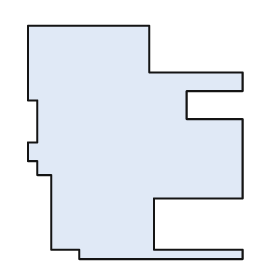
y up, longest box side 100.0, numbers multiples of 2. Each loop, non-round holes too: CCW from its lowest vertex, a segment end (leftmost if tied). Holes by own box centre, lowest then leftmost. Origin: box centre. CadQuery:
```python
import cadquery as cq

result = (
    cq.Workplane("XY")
    .moveTo(-24.0, -50.0)
    .lineTo(46.0, -50.0)
    .lineTo(46.0, -46.0)
    .lineTo(8.0, -46.0)
    .lineTo(8.0, -24.0)
    .lineTo(46.0, -24.0)
    .lineTo(46.0, 10.0)
    .lineTo(22.0, 10.0)
    .lineTo(22.0, 22.0)
    .lineTo(46.0, 22.0)
    .lineTo(46.0, 30.0)
    .lineTo(6.0, 30.0)
    .lineTo(6.0, 50.0)
    .lineTo(-46.0, 50.0)
    .lineTo(-46.0, 18.0)
    .lineTo(-42.0, 18.0)
    .lineTo(-42.0, 0.0)
    .lineTo(-46.0, 0.0)
    .lineTo(-46.0, -8.0)
    .lineTo(-42.0, -8.0)
    .lineTo(-42.0, -14.0)
    .lineTo(-36.0, -14.0)
    .lineTo(-36.0, -46.0)
    .lineTo(-24.0, -46.0)
    .close()
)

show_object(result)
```